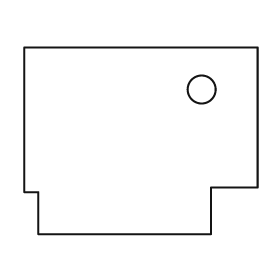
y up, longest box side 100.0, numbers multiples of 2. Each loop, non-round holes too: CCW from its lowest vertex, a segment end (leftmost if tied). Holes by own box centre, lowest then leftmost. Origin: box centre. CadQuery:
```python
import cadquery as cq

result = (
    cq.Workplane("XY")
    .moveTo(-44.0, -40.0)
    .lineTo(30.0, -40.0)
    .lineTo(30.0, -20.0)
    .lineTo(50.0, -20.0)
    .lineTo(50.0, 40.0)
    .lineTo(-50.0, 40.0)
    .lineTo(-50.0, -22.0)
    .lineTo(-44.0, -22.0)
    .close()
    .moveTo(26.0, 22.0)
    .circle(6.0)
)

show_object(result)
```